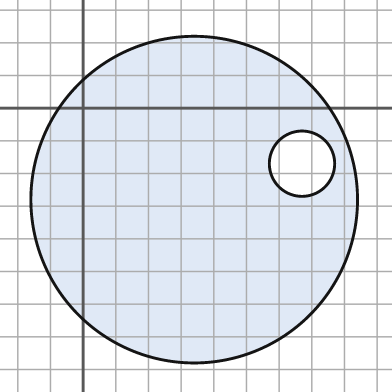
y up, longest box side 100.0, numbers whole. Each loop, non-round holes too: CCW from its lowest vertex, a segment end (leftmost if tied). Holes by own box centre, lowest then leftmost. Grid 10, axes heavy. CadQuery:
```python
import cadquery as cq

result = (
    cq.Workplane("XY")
    .moveTo(34.0, -28.0)
    .circle(50.0)
    .moveTo(67.0, -17.0)
    .circle(10.0)
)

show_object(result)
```